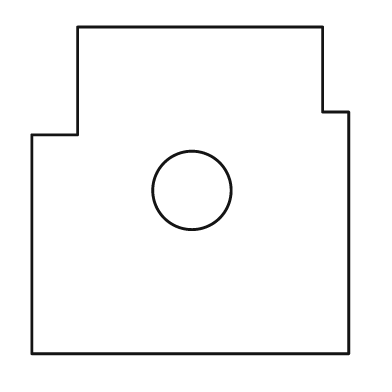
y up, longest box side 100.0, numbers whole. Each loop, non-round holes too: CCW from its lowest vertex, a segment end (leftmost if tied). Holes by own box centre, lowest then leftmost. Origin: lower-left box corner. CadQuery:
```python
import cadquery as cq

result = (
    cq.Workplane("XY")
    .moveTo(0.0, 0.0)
    .lineTo(97.0, 0.0)
    .lineTo(97.0, 74.0)
    .lineTo(89.0, 74.0)
    .lineTo(89.0, 100.0)
    .lineTo(14.0, 100.0)
    .lineTo(14.0, 67.0)
    .lineTo(0.0, 67.0)
    .close()
    .moveTo(49.0, 50.0)
    .circle(12.0)
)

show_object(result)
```